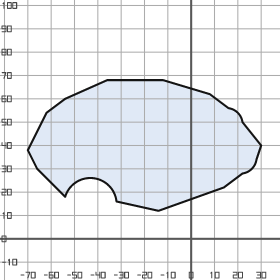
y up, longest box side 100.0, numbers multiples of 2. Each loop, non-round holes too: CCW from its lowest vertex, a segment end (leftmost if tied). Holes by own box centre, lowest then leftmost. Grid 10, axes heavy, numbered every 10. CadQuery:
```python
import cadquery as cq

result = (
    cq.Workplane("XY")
    .moveTo(-14.0, 12.0)
    .lineTo(14.0, 22.0)
    .lineTo(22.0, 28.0)
    .threePointArc((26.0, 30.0), (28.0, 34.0))
    .lineTo(30.0, 40.0)
    .lineTo(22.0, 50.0)
    .threePointArc((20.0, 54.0), (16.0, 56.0))
    .lineTo(8.0, 62.0)
    .lineTo(-12.0, 68.0)
    .lineTo(-36.0, 68.0)
    .lineTo(-54.0, 60.0)
    .lineTo(-62.0, 54.0)
    .lineTo(-70.0, 38.0)
    .lineTo(-66.0, 30.0)
    .lineTo(-54.0, 18.0)
    .threePointArc((-42.0, 26.0), (-32.0, 16.0))
    .close()
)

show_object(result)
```